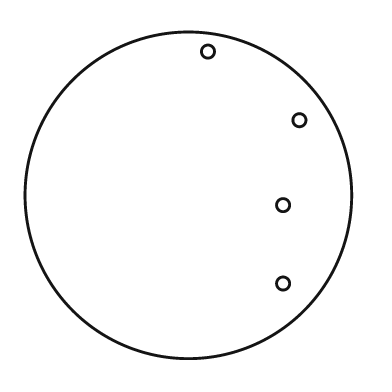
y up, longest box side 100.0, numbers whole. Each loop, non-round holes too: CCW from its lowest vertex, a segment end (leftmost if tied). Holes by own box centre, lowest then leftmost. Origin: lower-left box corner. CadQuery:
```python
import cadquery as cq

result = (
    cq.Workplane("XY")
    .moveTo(50.0, 50.0)
    .circle(50.0)
    .moveTo(79.0, 23.0)
    .circle(2.0)
    .moveTo(79.0, 47.0)
    .circle(2.0)
    .moveTo(84.0, 73.0)
    .circle(2.0)
    .moveTo(56.0, 94.0)
    .circle(2.0)
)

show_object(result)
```